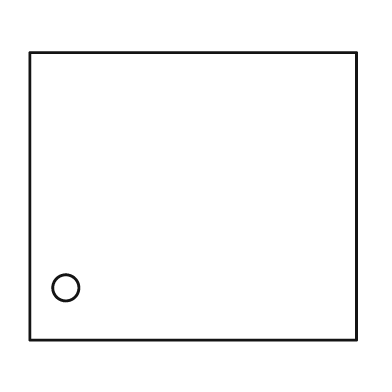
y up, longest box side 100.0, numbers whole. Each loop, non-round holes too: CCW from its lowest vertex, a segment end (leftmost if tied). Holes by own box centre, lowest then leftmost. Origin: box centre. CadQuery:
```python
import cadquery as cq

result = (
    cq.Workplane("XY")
    .moveTo(-50.0, -44.0)
    .lineTo(50.0, -44.0)
    .lineTo(50.0, 44.0)
    .lineTo(-50.0, 44.0)
    .close()
    .moveTo(-39.0, -28.0)
    .circle(4.0)
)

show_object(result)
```